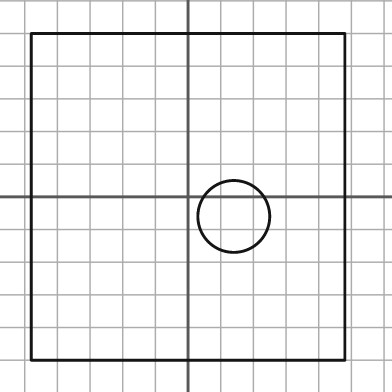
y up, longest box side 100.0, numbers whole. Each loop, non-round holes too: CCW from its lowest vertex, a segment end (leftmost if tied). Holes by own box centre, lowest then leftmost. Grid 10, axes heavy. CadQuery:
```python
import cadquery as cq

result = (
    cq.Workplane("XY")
    .moveTo(-48.0, -50.0)
    .lineTo(48.0, -50.0)
    .lineTo(48.0, 50.0)
    .lineTo(-48.0, 50.0)
    .close()
    .moveTo(14.0, -6.0)
    .circle(11.0)
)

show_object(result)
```